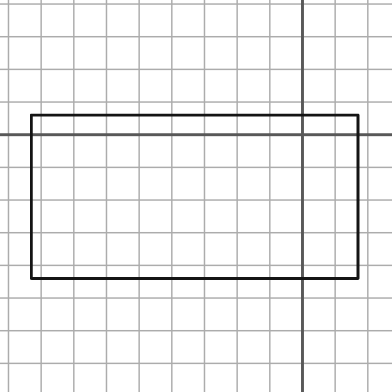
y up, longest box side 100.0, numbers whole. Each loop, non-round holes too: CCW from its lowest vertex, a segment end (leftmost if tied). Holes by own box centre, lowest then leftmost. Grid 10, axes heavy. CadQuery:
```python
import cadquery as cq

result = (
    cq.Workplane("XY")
    .moveTo(-83.0, -44.0)
    .lineTo(17.0, -44.0)
    .lineTo(17.0, 6.0)
    .lineTo(-83.0, 6.0)
    .close()
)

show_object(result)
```